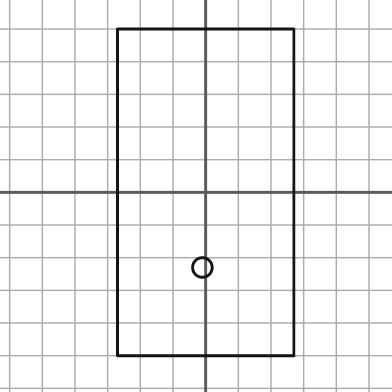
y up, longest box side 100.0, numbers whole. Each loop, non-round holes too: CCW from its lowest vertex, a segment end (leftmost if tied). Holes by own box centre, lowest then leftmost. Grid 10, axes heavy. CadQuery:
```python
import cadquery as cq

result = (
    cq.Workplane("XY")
    .moveTo(-27.0, -50.0)
    .lineTo(27.0, -50.0)
    .lineTo(27.0, 50.0)
    .lineTo(-27.0, 50.0)
    .close()
    .moveTo(-1.0, -23.0)
    .circle(3.0)
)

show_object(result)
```